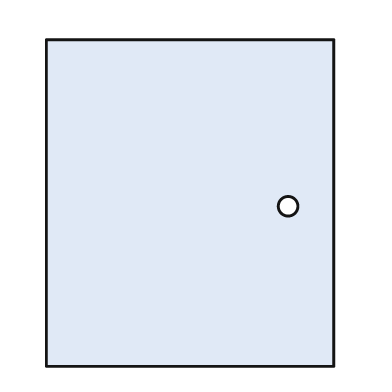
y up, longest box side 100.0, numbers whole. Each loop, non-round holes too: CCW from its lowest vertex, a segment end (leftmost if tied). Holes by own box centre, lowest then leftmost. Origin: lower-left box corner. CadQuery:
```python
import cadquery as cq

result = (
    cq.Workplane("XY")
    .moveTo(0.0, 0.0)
    .lineTo(88.0, 0.0)
    .lineTo(88.0, 100.0)
    .lineTo(0.0, 100.0)
    .close()
    .moveTo(74.0, 49.0)
    .circle(3.0)
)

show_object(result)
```